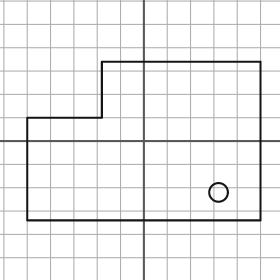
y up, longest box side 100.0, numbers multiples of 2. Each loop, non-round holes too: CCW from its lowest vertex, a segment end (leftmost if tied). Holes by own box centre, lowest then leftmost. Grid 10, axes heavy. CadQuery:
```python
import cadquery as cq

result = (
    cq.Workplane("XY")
    .moveTo(-50.0, -34.0)
    .lineTo(50.0, -34.0)
    .lineTo(50.0, 34.0)
    .lineTo(-18.0, 34.0)
    .lineTo(-18.0, 10.0)
    .lineTo(-50.0, 10.0)
    .close()
    .moveTo(32.0, -22.0)
    .circle(4.0)
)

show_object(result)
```